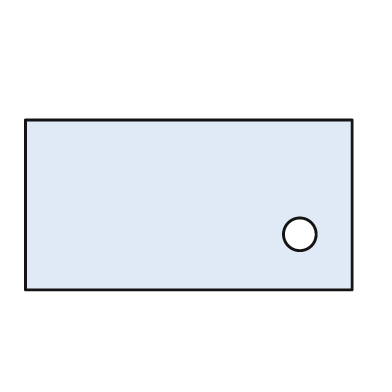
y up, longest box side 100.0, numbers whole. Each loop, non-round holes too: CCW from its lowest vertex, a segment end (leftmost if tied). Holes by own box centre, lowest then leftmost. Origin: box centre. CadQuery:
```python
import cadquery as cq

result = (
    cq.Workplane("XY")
    .moveTo(-50.0, -26.0)
    .lineTo(50.0, -26.0)
    .lineTo(50.0, 26.0)
    .lineTo(-50.0, 26.0)
    .close()
    .moveTo(34.0, -9.0)
    .circle(5.0)
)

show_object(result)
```